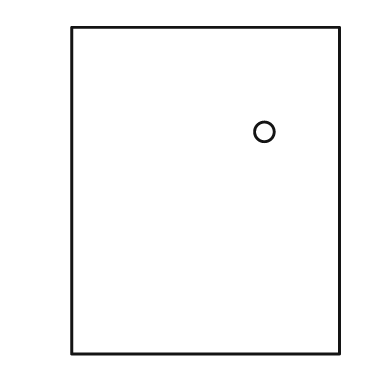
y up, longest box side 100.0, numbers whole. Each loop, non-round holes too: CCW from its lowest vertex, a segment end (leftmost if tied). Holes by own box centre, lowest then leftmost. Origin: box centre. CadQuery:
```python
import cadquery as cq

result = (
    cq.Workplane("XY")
    .moveTo(-41.0, -50.0)
    .lineTo(41.0, -50.0)
    .lineTo(41.0, 50.0)
    .lineTo(-41.0, 50.0)
    .close()
    .moveTo(18.0, 18.0)
    .circle(3.0)
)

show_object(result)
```